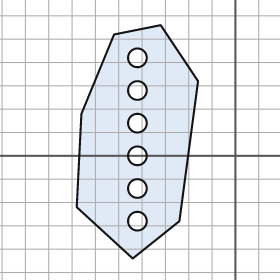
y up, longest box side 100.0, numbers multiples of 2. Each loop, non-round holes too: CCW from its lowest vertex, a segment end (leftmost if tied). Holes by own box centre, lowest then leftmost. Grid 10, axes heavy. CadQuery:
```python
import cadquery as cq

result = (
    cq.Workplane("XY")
    .moveTo(-44.0, -44.0)
    .lineTo(-24.0, -28.0)
    .lineTo(-16.0, 32.0)
    .lineTo(-32.0, 56.0)
    .lineTo(-52.0, 52.0)
    .lineTo(-66.0, 18.0)
    .lineTo(-68.0, -22.0)
    .close()
    .moveTo(-42.0, -28.0)
    .circle(4.0)
    .moveTo(-42.0, -14.0)
    .circle(4.0)
    .moveTo(-42.0, 0.0)
    .circle(4.0)
    .moveTo(-42.0, 14.0)
    .circle(4.0)
    .moveTo(-42.0, 28.0)
    .circle(4.0)
    .moveTo(-42.0, 42.0)
    .circle(4.0)
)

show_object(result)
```